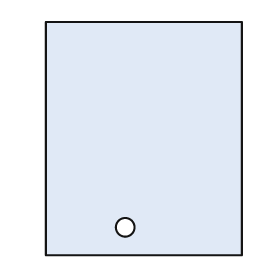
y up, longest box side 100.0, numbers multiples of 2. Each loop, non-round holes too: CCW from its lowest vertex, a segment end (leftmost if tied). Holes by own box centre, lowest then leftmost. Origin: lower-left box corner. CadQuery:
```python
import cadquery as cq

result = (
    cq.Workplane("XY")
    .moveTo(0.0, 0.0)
    .lineTo(84.0, 0.0)
    .lineTo(84.0, 100.0)
    .lineTo(0.0, 100.0)
    .close()
    .moveTo(34.0, 12.0)
    .circle(4.0)
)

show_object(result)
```